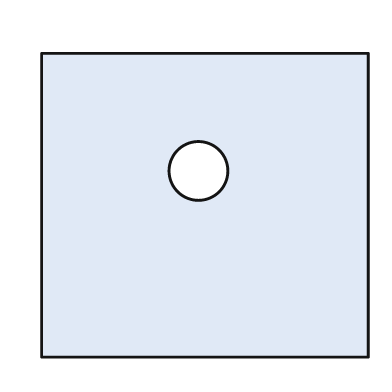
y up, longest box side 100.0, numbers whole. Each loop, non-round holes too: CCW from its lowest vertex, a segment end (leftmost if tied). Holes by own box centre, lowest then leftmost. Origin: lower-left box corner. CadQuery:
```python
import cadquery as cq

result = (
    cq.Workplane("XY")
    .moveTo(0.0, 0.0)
    .lineTo(100.0, 0.0)
    .lineTo(100.0, 93.0)
    .lineTo(0.0, 93.0)
    .close()
    .moveTo(48.0, 57.0)
    .circle(9.0)
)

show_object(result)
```